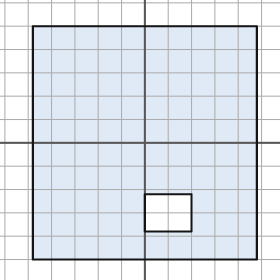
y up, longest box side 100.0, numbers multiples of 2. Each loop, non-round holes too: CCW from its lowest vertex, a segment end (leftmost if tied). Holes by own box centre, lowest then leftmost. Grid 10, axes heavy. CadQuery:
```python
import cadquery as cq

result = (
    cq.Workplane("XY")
    .moveTo(-48.0, -50.0)
    .lineTo(48.0, -50.0)
    .lineTo(48.0, 50.0)
    .lineTo(-48.0, 50.0)
    .close()
    .moveTo(0.0, -38.0)
    .lineTo(20.0, -38.0)
    .lineTo(20.0, -22.0)
    .lineTo(0.0, -22.0)
    .close()
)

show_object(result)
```